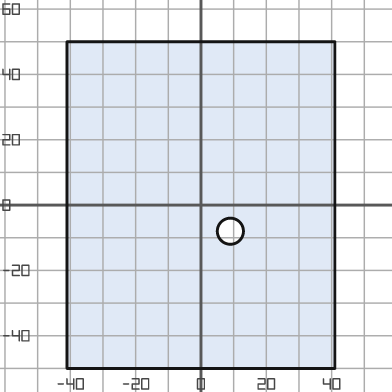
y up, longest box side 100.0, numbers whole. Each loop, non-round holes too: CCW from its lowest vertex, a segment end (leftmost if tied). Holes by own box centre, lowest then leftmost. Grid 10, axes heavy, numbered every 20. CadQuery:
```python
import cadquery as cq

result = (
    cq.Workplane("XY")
    .moveTo(-41.0, -50.0)
    .lineTo(41.0, -50.0)
    .lineTo(41.0, 50.0)
    .lineTo(-41.0, 50.0)
    .close()
    .moveTo(9.0, -8.0)
    .circle(4.0)
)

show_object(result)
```